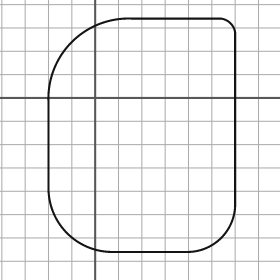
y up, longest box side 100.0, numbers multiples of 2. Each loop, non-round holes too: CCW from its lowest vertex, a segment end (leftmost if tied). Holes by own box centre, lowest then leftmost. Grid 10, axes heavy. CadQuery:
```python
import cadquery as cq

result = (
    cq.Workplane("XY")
    .moveTo(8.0, -66.0)
    .lineTo(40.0, -66.0)
    .threePointArc((54.0, -60.0), (60.0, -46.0))
    .lineTo(60.0, 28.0)
    .threePointArc((58.0, 32.0), (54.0, 34.0))
    .lineTo(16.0, 34.0)
    .threePointArc((-10.0, 24.0), (-20.0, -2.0))
    .lineTo(-20.0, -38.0)
    .threePointArc((-12.0, -58.0), (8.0, -66.0))
    .close()
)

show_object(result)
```